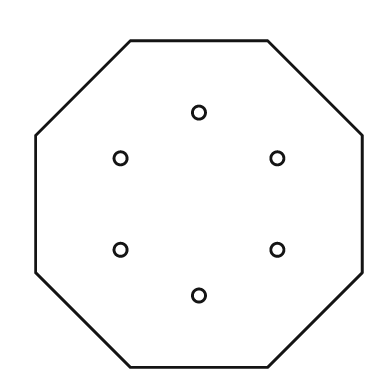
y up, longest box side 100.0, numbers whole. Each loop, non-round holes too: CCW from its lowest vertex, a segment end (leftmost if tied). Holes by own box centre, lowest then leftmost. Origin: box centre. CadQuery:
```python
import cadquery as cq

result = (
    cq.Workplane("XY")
    .moveTo(-21.0, -50.0)
    .lineTo(21.0, -50.0)
    .lineTo(50.0, -21.0)
    .lineTo(50.0, 21.0)
    .lineTo(21.0, 50.0)
    .lineTo(-21.0, 50.0)
    .lineTo(-50.0, 21.0)
    .lineTo(-50.0, -21.0)
    .close()
    .moveTo(0.0, -28.0)
    .circle(2.0)
    .moveTo(-24.0, -14.0)
    .circle(2.0)
    .moveTo(24.0, -14.0)
    .circle(2.0)
    .moveTo(-24.0, 14.0)
    .circle(2.0)
    .moveTo(24.0, 14.0)
    .circle(2.0)
    .moveTo(0.0, 28.0)
    .circle(2.0)
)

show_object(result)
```